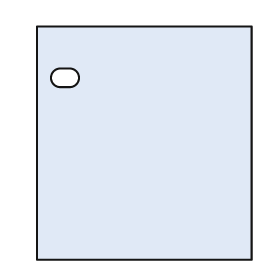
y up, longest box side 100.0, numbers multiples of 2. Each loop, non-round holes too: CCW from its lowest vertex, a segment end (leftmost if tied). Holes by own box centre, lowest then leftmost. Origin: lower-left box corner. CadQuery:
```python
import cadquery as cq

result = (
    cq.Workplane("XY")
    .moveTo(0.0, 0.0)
    .lineTo(92.0, 0.0)
    .lineTo(92.0, 100.0)
    .lineTo(0.0, 100.0)
    .close()
    .moveTo(10.0, 74.0)
    .lineTo(14.0, 74.0)
    .threePointArc((18.0, 78.0), (14.0, 82.0))
    .lineTo(10.0, 82.0)
    .threePointArc((6.0, 78.0), (10.0, 74.0))
    .close()
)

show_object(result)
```